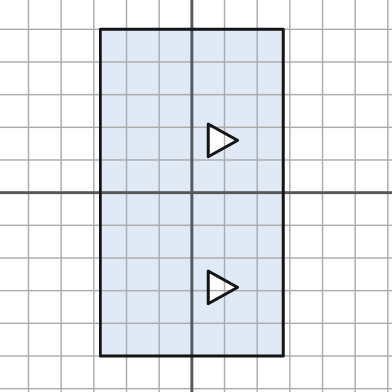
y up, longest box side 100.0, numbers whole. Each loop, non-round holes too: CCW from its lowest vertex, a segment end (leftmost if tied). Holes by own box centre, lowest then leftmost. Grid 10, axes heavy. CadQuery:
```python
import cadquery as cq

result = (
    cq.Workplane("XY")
    .moveTo(-28.0, -50.0)
    .lineTo(28.0, -50.0)
    .lineTo(28.0, 50.0)
    .lineTo(-28.0, 50.0)
    .close()
    .moveTo(5.0, -34.0)
    .lineTo(14.0, -29.0)
    .lineTo(5.0, -24.0)
    .close()
    .moveTo(5.0, 11.0)
    .lineTo(14.0, 16.0)
    .lineTo(5.0, 21.0)
    .close()
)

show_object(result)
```